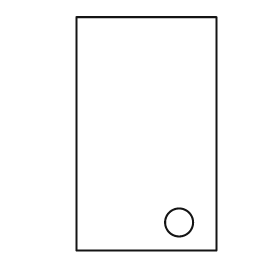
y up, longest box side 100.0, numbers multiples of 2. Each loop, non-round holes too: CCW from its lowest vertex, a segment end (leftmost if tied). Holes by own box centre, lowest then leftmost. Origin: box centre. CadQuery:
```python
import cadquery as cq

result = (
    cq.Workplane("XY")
    .moveTo(-30.0, -50.0)
    .lineTo(30.0, -50.0)
    .lineTo(30.0, 50.0)
    .lineTo(-30.0, 50.0)
    .close()
    .moveTo(14.0, -38.0)
    .circle(6.0)
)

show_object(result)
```